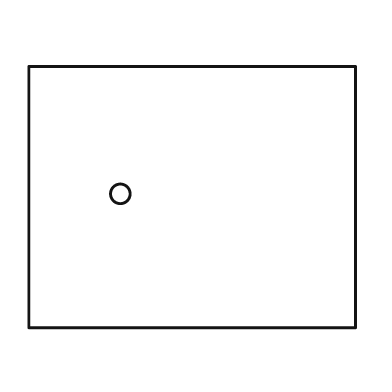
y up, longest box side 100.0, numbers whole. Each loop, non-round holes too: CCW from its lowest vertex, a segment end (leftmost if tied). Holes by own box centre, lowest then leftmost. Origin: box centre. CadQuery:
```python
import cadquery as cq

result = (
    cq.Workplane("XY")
    .moveTo(-50.0, -40.0)
    .lineTo(50.0, -40.0)
    .lineTo(50.0, 40.0)
    .lineTo(-50.0, 40.0)
    .close()
    .moveTo(-22.0, 1.0)
    .circle(3.0)
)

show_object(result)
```